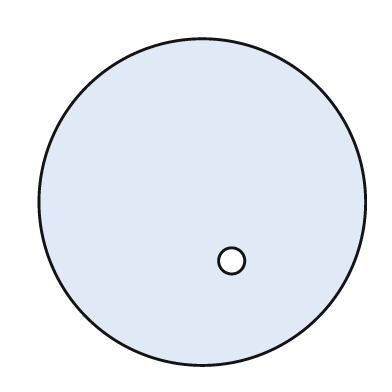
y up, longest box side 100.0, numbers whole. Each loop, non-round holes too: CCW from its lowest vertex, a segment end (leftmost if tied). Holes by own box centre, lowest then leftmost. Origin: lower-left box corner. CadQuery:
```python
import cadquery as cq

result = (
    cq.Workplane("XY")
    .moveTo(50.0, 50.0)
    .circle(50.0)
    .moveTo(59.0, 32.0)
    .circle(4.0)
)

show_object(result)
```